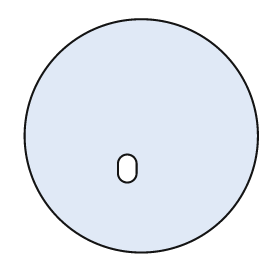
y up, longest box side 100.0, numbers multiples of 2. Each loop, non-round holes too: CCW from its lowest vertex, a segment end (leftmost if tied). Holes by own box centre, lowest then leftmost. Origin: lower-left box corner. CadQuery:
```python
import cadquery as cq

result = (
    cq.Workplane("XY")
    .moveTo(50.0, 50.0)
    .circle(50.0)
    .moveTo(40.0, 34.0)
    .threePointArc((44.0, 30.0), (48.0, 34.0))
    .lineTo(48.0, 38.0)
    .threePointArc((44.0, 42.0), (40.0, 38.0))
    .close()
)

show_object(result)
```